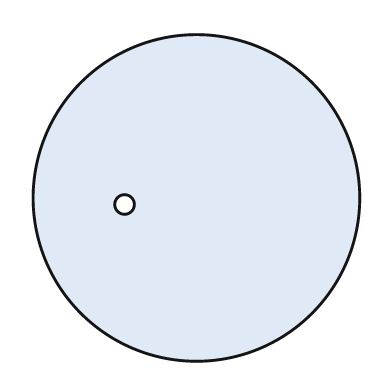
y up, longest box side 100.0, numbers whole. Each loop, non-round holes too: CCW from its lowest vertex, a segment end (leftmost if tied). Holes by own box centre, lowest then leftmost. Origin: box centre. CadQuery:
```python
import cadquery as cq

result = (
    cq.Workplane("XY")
    .moveTo(0.0, 0.0)
    .circle(50.0)
    .moveTo(-22.0, -2.0)
    .circle(3.0)
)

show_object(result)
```